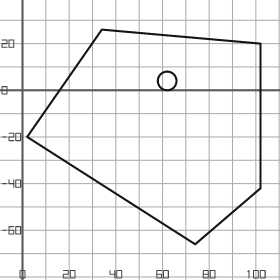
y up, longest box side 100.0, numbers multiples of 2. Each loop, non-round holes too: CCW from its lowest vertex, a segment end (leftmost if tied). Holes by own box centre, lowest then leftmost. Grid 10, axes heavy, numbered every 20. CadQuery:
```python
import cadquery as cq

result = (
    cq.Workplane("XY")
    .moveTo(74.0, -66.0)
    .lineTo(102.0, -42.0)
    .lineTo(102.0, 20.0)
    .lineTo(34.0, 26.0)
    .lineTo(2.0, -20.0)
    .close()
    .moveTo(62.0, 4.0)
    .circle(4.0)
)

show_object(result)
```